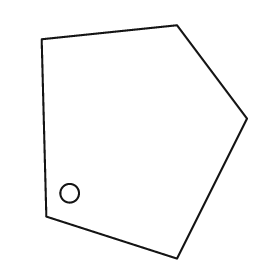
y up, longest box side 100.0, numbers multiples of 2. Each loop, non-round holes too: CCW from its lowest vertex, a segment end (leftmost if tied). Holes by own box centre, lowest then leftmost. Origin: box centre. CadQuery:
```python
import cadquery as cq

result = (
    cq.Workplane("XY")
    .moveTo(14.0, -50.0)
    .lineTo(44.0, 10.0)
    .lineTo(14.0, 50.0)
    .lineTo(-44.0, 44.0)
    .lineTo(-42.0, -32.0)
    .close()
    .moveTo(-32.0, -22.0)
    .circle(4.0)
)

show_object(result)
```